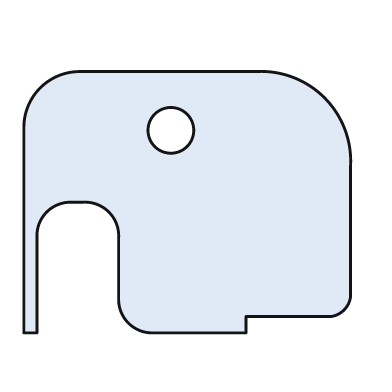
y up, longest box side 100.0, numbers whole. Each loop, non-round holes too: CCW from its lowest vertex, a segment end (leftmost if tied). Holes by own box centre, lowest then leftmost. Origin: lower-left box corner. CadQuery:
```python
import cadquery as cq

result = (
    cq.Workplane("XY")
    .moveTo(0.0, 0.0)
    .lineTo(4.0, 0.0)
    .lineTo(4.0, 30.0)
    .threePointArc((7.0, 37.0), (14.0, 40.0))
    .lineTo(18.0, 40.0)
    .threePointArc((26.0, 37.0), (29.0, 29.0))
    .lineTo(29.0, 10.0)
    .threePointArc((32.0, 3.0), (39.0, 0.0))
    .lineTo(68.0, 0.0)
    .lineTo(68.0, 5.0)
    .lineTo(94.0, 5.0)
    .threePointArc((98.0, 7.0), (100.0, 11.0))
    .lineTo(100.0, 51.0)
    .threePointArc((92.0, 72.0), (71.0, 80.0))
    .lineTo(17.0, 80.0)
    .threePointArc((5.0, 75.0), (0.0, 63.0))
    .close()
    .moveTo(45.0, 62.0)
    .circle(7.0)
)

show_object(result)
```